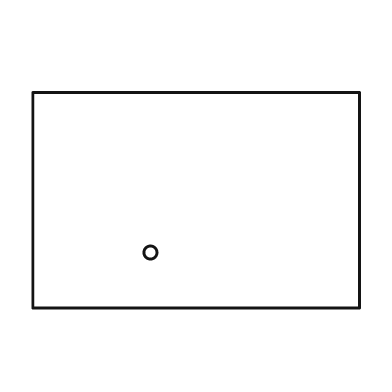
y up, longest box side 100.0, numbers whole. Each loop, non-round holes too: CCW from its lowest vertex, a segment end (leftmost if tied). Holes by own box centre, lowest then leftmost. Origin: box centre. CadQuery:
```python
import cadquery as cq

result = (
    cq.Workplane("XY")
    .moveTo(-50.0, -33.0)
    .lineTo(50.0, -33.0)
    .lineTo(50.0, 33.0)
    .lineTo(-50.0, 33.0)
    .close()
    .moveTo(-14.0, -16.0)
    .circle(2.0)
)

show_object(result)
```